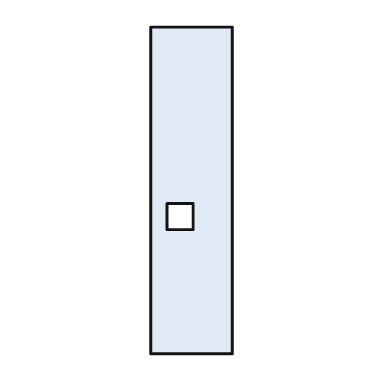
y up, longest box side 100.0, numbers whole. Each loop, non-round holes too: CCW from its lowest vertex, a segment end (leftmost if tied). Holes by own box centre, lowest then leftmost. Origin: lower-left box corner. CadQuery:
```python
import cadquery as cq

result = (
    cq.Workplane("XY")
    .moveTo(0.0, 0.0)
    .lineTo(25.0, 0.0)
    .lineTo(25.0, 100.0)
    .lineTo(0.0, 100.0)
    .close()
    .moveTo(5.0, 38.0)
    .lineTo(13.0, 38.0)
    .lineTo(13.0, 46.0)
    .lineTo(5.0, 46.0)
    .close()
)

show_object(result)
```